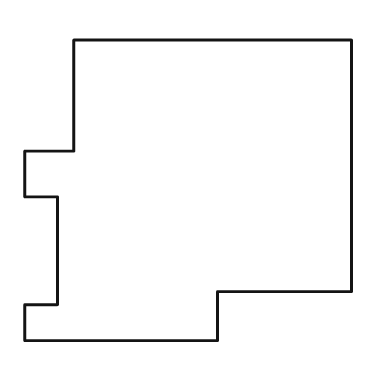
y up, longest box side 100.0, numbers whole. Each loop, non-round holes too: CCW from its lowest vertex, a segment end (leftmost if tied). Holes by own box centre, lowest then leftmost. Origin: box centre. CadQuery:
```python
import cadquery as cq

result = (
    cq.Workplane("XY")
    .moveTo(-50.0, -46.0)
    .lineTo(9.0, -46.0)
    .lineTo(9.0, -31.0)
    .lineTo(50.0, -31.0)
    .lineTo(50.0, 46.0)
    .lineTo(-35.0, 46.0)
    .lineTo(-35.0, 12.0)
    .lineTo(-50.0, 12.0)
    .lineTo(-50.0, -2.0)
    .lineTo(-40.0, -2.0)
    .lineTo(-40.0, -35.0)
    .lineTo(-50.0, -35.0)
    .close()
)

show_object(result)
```